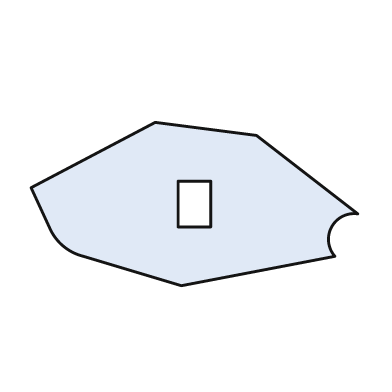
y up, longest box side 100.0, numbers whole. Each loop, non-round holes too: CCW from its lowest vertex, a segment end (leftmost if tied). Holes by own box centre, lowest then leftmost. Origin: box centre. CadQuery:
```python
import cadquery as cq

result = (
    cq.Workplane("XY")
    .moveTo(-4.0, -25.0)
    .lineTo(43.0, -16.0)
    .threePointArc((42.0, -7.0), (50.0, -3.0))
    .lineTo(19.0, 21.0)
    .lineTo(-12.0, 25.0)
    .lineTo(-50.0, 5.0)
    .lineTo(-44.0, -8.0)
    .threePointArc((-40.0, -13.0), (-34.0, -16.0))
    .close()
    .moveTo(-5.0, -7.0)
    .lineTo(5.0, -7.0)
    .lineTo(5.0, 7.0)
    .lineTo(-5.0, 7.0)
    .close()
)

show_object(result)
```